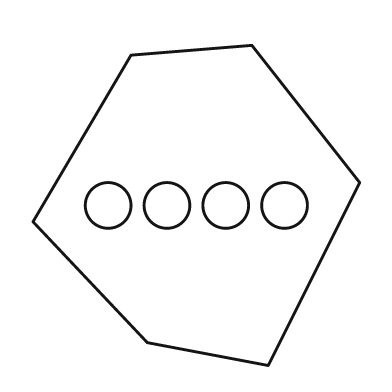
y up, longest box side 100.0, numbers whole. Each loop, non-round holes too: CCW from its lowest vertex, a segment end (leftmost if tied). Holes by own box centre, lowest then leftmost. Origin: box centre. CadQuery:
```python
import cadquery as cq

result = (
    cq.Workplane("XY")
    .moveTo(22.0, -49.0)
    .lineTo(50.0, 7.0)
    .lineTo(17.0, 49.0)
    .lineTo(-20.0, 46.0)
    .lineTo(-50.0, -5.0)
    .lineTo(-15.0, -42.0)
    .close()
    .moveTo(-27.0, 0.0)
    .circle(7.0)
    .moveTo(-9.0, 0.0)
    .circle(7.0)
    .moveTo(9.0, 0.0)
    .circle(7.0)
    .moveTo(27.0, 0.0)
    .circle(7.0)
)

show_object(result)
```